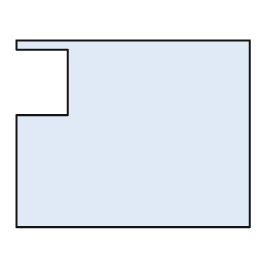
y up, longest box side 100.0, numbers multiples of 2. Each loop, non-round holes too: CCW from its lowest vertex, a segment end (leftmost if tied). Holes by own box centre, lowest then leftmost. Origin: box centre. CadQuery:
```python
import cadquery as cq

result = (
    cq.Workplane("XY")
    .moveTo(-50.0, -40.0)
    .lineTo(50.0, -40.0)
    .lineTo(50.0, 40.0)
    .lineTo(-50.0, 40.0)
    .lineTo(-50.0, 36.0)
    .lineTo(-28.0, 36.0)
    .lineTo(-28.0, 8.0)
    .lineTo(-50.0, 8.0)
    .close()
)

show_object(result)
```